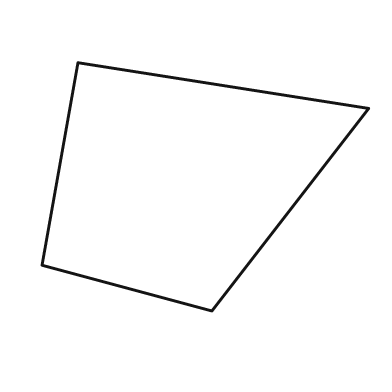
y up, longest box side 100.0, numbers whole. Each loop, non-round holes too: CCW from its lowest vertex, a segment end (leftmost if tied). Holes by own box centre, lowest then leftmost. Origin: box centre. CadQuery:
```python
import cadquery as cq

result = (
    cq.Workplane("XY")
    .moveTo(2.0, -38.0)
    .lineTo(50.0, 24.0)
    .lineTo(-39.0, 38.0)
    .lineTo(-50.0, -24.0)
    .close()
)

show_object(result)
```